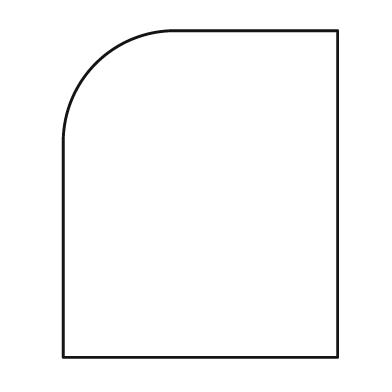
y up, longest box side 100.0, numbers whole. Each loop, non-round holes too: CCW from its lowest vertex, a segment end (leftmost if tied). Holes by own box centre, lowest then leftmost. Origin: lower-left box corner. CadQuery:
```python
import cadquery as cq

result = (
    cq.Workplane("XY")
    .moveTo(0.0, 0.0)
    .lineTo(84.0, 0.0)
    .lineTo(84.0, 100.0)
    .lineTo(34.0, 100.0)
    .threePointArc((10.0, 90.0), (0.0, 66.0))
    .close()
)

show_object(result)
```